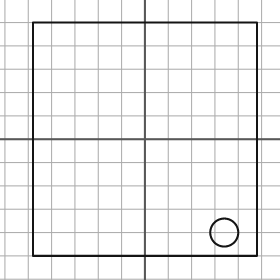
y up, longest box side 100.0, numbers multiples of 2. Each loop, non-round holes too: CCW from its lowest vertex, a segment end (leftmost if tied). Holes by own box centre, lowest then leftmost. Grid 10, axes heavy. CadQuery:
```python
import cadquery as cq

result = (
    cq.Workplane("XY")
    .moveTo(-48.0, -50.0)
    .lineTo(48.0, -50.0)
    .lineTo(48.0, 50.0)
    .lineTo(-48.0, 50.0)
    .close()
    .moveTo(34.0, -40.0)
    .circle(6.0)
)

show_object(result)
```